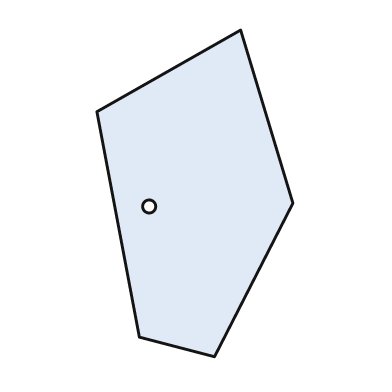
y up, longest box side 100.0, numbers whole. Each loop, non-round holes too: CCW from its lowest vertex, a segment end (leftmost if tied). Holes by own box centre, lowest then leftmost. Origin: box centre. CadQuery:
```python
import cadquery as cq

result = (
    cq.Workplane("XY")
    .moveTo(6.0, -50.0)
    .lineTo(30.0, -3.0)
    .lineTo(14.0, 50.0)
    .lineTo(-30.0, 25.0)
    .lineTo(-17.0, -44.0)
    .close()
    .moveTo(-14.0, -4.0)
    .circle(2.0)
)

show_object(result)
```